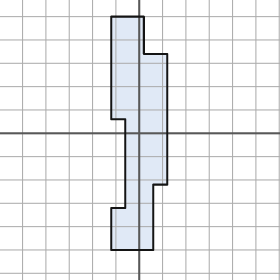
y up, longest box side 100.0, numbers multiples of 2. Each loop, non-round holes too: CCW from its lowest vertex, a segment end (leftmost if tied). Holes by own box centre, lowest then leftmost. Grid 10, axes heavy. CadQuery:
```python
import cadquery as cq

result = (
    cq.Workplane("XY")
    .moveTo(-12.0, -50.0)
    .lineTo(6.0, -50.0)
    .lineTo(6.0, -22.0)
    .lineTo(12.0, -22.0)
    .lineTo(12.0, 34.0)
    .lineTo(2.0, 34.0)
    .lineTo(2.0, 50.0)
    .lineTo(-12.0, 50.0)
    .lineTo(-12.0, 6.0)
    .lineTo(-6.0, 6.0)
    .lineTo(-6.0, -32.0)
    .lineTo(-12.0, -32.0)
    .close()
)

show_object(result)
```